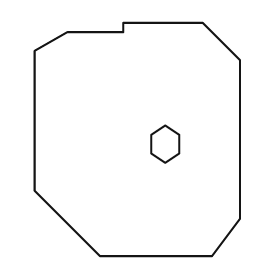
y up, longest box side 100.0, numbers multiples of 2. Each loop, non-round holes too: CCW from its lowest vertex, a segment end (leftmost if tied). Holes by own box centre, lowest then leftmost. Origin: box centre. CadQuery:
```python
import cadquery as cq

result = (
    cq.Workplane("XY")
    .moveTo(-16.0, -50.0)
    .lineTo(32.0, -50.0)
    .lineTo(44.0, -34.0)
    .lineTo(44.0, 34.0)
    .lineTo(28.0, 50.0)
    .lineTo(-6.0, 50.0)
    .lineTo(-6.0, 46.0)
    .lineTo(-30.0, 46.0)
    .lineTo(-44.0, 38.0)
    .lineTo(-44.0, -22.0)
    .close()
    .moveTo(12.0, -10.0)
    .lineTo(18.0, -6.0)
    .lineTo(18.0, 2.0)
    .lineTo(12.0, 6.0)
    .lineTo(6.0, 2.0)
    .lineTo(6.0, -6.0)
    .close()
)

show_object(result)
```